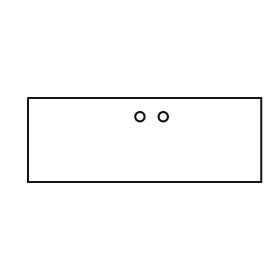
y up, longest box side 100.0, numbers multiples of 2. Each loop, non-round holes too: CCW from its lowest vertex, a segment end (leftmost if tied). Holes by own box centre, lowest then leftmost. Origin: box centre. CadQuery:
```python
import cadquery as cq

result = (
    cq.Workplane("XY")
    .moveTo(-50.0, -18.0)
    .lineTo(50.0, -18.0)
    .lineTo(50.0, 18.0)
    .lineTo(-50.0, 18.0)
    .close()
    .moveTo(-2.0, 10.0)
    .circle(2.0)
    .moveTo(8.0, 10.0)
    .circle(2.0)
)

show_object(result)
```